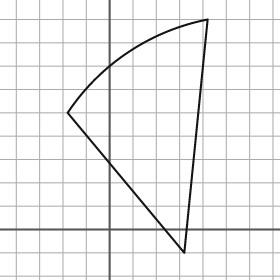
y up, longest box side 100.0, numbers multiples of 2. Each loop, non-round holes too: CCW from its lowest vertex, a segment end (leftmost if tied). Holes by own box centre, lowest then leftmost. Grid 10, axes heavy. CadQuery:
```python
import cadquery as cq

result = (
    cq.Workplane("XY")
    .moveTo(32.0, -10.0)
    .lineTo(42.0, 90.0)
    .threePointArc((8.0, 76.0), (-18.0, 50.0))
    .close()
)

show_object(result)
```